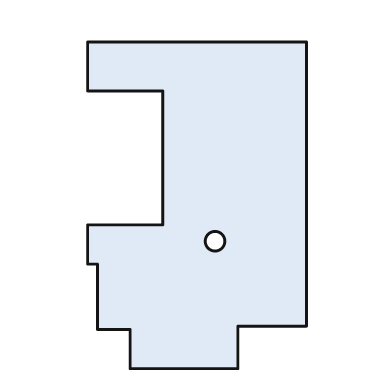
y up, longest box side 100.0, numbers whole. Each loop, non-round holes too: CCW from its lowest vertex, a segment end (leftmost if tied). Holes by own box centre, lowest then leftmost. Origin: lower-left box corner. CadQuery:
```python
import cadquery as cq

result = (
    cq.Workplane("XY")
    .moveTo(13.0, 0.0)
    .lineTo(46.0, 0.0)
    .lineTo(46.0, 13.0)
    .lineTo(67.0, 13.0)
    .lineTo(67.0, 100.0)
    .lineTo(0.0, 100.0)
    .lineTo(0.0, 85.0)
    .lineTo(23.0, 85.0)
    .lineTo(23.0, 44.0)
    .lineTo(0.0, 44.0)
    .lineTo(0.0, 32.0)
    .lineTo(3.0, 32.0)
    .lineTo(3.0, 12.0)
    .lineTo(13.0, 12.0)
    .close()
    .moveTo(39.0, 39.0)
    .circle(3.0)
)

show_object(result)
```